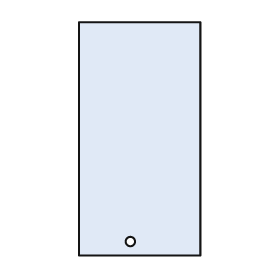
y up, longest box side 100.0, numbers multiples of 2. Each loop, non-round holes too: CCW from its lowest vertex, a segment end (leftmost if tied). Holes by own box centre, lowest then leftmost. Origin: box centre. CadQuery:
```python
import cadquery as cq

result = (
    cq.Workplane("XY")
    .moveTo(-26.0, -50.0)
    .lineTo(26.0, -50.0)
    .lineTo(26.0, 50.0)
    .lineTo(-26.0, 50.0)
    .close()
    .moveTo(-4.0, -44.0)
    .circle(2.0)
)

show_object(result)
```